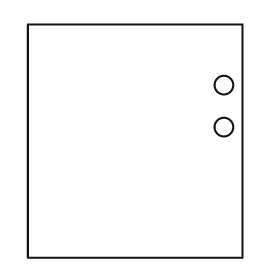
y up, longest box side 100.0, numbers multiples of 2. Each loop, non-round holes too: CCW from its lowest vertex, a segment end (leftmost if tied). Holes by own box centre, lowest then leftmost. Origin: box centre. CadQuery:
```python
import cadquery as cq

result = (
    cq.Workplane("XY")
    .moveTo(-46.0, -50.0)
    .lineTo(46.0, -50.0)
    .lineTo(46.0, 50.0)
    .lineTo(-46.0, 50.0)
    .close()
    .moveTo(38.0, 6.0)
    .circle(4.0)
    .moveTo(38.0, 24.0)
    .circle(4.0)
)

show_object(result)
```